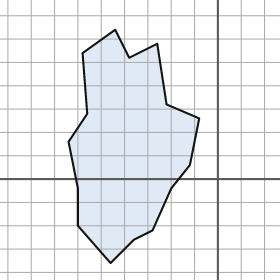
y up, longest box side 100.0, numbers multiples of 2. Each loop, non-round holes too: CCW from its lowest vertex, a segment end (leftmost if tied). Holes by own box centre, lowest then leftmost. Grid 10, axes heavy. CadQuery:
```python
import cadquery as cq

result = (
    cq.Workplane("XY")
    .moveTo(-46.0, -36.0)
    .lineTo(-36.0, -26.0)
    .lineTo(-28.0, -22.0)
    .lineTo(-20.0, -4.0)
    .lineTo(-12.0, 6.0)
    .lineTo(-8.0, 26.0)
    .lineTo(-22.0, 32.0)
    .lineTo(-26.0, 58.0)
    .lineTo(-38.0, 52.0)
    .lineTo(-44.0, 64.0)
    .lineTo(-58.0, 54.0)
    .lineTo(-56.0, 28.0)
    .lineTo(-64.0, 16.0)
    .lineTo(-60.0, -4.0)
    .lineTo(-60.0, -20.0)
    .close()
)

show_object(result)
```